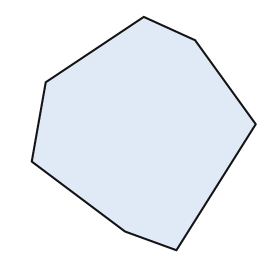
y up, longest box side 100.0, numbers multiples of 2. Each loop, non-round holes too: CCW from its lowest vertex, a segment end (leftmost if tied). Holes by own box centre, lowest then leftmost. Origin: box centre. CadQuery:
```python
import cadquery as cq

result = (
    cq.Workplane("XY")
    .moveTo(14.0, -50.0)
    .lineTo(48.0, 4.0)
    .lineTo(22.0, 40.0)
    .lineTo(0.0, 50.0)
    .lineTo(-42.0, 22.0)
    .lineTo(-48.0, -12.0)
    .lineTo(-8.0, -42.0)
    .close()
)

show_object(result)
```